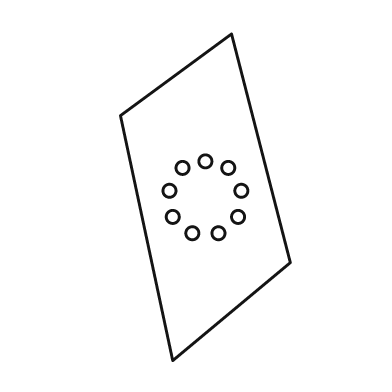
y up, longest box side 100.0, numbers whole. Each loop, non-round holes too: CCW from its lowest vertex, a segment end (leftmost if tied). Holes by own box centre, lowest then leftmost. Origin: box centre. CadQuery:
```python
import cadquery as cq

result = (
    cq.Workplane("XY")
    .moveTo(-10.0, -50.0)
    .lineTo(26.0, -20.0)
    .lineTo(8.0, 50.0)
    .lineTo(-26.0, 25.0)
    .close()
    .moveTo(-4.0, -11.0)
    .circle(2.0)
    .moveTo(4.0, -11.0)
    .circle(2.0)
    .moveTo(-10.0, -6.0)
    .circle(2.0)
    .moveTo(10.0, -6.0)
    .circle(2.0)
    .moveTo(-11.0, 2.0)
    .circle(2.0)
    .moveTo(11.0, 2.0)
    .circle(2.0)
    .moveTo(-7.0, 9.0)
    .circle(2.0)
    .moveTo(7.0, 9.0)
    .circle(2.0)
    .moveTo(0.0, 11.0)
    .circle(2.0)
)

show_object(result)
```